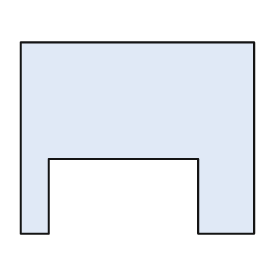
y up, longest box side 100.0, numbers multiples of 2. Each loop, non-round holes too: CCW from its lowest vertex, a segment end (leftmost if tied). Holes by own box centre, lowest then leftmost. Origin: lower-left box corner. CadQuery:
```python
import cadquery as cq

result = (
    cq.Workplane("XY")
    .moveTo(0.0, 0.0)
    .lineTo(12.0, 0.0)
    .lineTo(12.0, 32.0)
    .lineTo(76.0, 32.0)
    .lineTo(76.0, 0.0)
    .lineTo(100.0, 0.0)
    .lineTo(100.0, 82.0)
    .lineTo(0.0, 82.0)
    .close()
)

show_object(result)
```